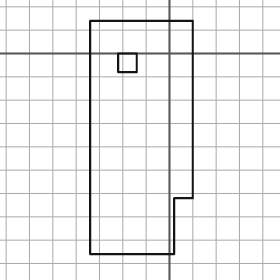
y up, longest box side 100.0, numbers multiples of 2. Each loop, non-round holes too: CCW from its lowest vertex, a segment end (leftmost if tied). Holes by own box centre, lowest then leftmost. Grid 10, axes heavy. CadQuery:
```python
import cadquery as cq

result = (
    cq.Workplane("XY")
    .moveTo(-34.0, -86.0)
    .lineTo(2.0, -86.0)
    .lineTo(2.0, -62.0)
    .lineTo(10.0, -62.0)
    .lineTo(10.0, 14.0)
    .lineTo(-34.0, 14.0)
    .close()
    .moveTo(-22.0, -8.0)
    .lineTo(-14.0, -8.0)
    .lineTo(-14.0, 0.0)
    .lineTo(-22.0, 0.0)
    .close()
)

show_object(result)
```